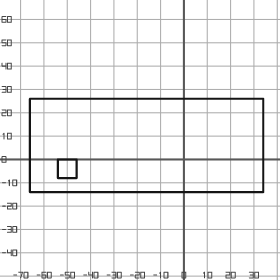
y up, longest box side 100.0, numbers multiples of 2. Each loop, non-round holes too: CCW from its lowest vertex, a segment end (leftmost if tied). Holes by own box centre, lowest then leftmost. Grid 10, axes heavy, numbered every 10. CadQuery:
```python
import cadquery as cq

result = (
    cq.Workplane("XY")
    .moveTo(-66.0, -14.0)
    .lineTo(34.0, -14.0)
    .lineTo(34.0, 26.0)
    .lineTo(-66.0, 26.0)
    .close()
    .moveTo(-54.0, -8.0)
    .lineTo(-46.0, -8.0)
    .lineTo(-46.0, 0.0)
    .lineTo(-54.0, 0.0)
    .close()
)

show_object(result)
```